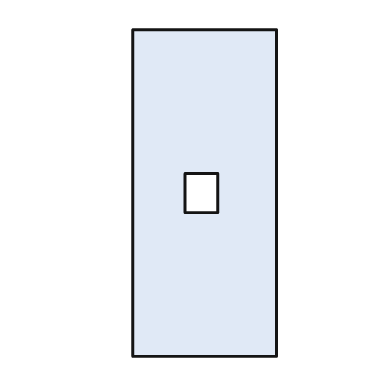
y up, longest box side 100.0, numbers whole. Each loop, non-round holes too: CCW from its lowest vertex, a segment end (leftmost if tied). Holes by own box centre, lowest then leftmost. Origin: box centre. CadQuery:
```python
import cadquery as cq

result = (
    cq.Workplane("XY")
    .moveTo(-22.0, -50.0)
    .lineTo(22.0, -50.0)
    .lineTo(22.0, 50.0)
    .lineTo(-22.0, 50.0)
    .close()
    .moveTo(-6.0, -6.0)
    .lineTo(4.0, -6.0)
    .lineTo(4.0, 6.0)
    .lineTo(-6.0, 6.0)
    .close()
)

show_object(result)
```